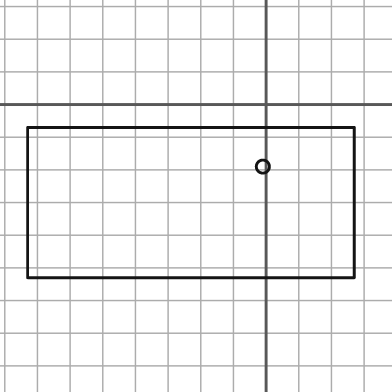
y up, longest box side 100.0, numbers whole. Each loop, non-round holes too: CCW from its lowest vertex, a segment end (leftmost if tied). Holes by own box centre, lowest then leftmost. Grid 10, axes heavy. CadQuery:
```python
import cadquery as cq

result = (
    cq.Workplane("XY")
    .moveTo(-73.0, -53.0)
    .lineTo(27.0, -53.0)
    .lineTo(27.0, -7.0)
    .lineTo(-73.0, -7.0)
    .close()
    .moveTo(-1.0, -19.0)
    .circle(2.0)
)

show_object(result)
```